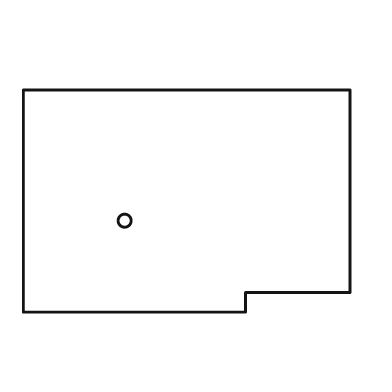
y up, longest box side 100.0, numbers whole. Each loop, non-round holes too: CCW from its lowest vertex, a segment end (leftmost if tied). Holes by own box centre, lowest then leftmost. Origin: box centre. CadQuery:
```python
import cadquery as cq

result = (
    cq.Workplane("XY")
    .moveTo(-50.0, -34.0)
    .lineTo(18.0, -34.0)
    .lineTo(18.0, -28.0)
    .lineTo(50.0, -28.0)
    .lineTo(50.0, 34.0)
    .lineTo(-50.0, 34.0)
    .close()
    .moveTo(-19.0, -6.0)
    .circle(2.0)
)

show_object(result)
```